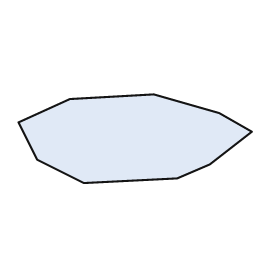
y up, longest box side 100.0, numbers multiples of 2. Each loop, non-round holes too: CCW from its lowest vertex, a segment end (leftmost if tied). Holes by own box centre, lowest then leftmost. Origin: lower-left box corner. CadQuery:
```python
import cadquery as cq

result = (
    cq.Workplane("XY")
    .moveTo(28.0, 0.0)
    .lineTo(68.0, 2.0)
    .lineTo(82.0, 8.0)
    .lineTo(100.0, 22.0)
    .lineTo(86.0, 30.0)
    .lineTo(58.0, 38.0)
    .lineTo(22.0, 36.0)
    .lineTo(0.0, 26.0)
    .lineTo(8.0, 10.0)
    .close()
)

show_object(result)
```